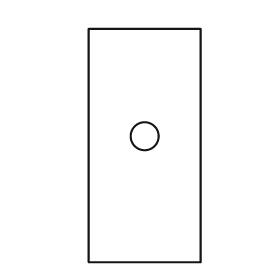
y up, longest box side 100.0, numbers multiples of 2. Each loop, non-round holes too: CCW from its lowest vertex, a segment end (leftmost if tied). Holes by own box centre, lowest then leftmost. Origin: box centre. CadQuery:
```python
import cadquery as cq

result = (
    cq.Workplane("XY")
    .moveTo(-24.0, -50.0)
    .lineTo(24.0, -50.0)
    .lineTo(24.0, 50.0)
    .lineTo(-24.0, 50.0)
    .close()
    .moveTo(0.0, 4.0)
    .circle(6.0)
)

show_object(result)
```